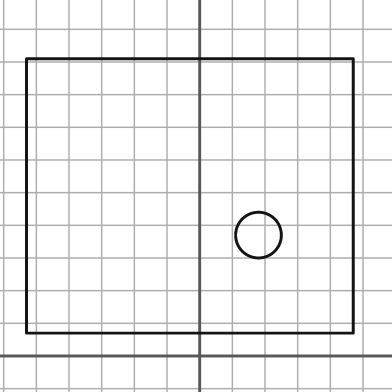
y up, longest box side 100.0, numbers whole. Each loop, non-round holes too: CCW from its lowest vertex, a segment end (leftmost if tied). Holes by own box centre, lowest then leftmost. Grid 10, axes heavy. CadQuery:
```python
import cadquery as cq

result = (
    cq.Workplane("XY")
    .moveTo(-53.0, 7.0)
    .lineTo(47.0, 7.0)
    .lineTo(47.0, 91.0)
    .lineTo(-53.0, 91.0)
    .close()
    .moveTo(18.0, 37.0)
    .circle(7.0)
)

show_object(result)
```